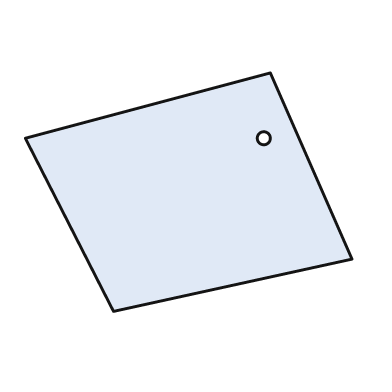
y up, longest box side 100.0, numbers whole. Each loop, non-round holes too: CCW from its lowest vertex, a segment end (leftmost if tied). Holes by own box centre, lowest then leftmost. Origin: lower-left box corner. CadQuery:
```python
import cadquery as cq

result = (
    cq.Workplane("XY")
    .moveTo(27.0, 0.0)
    .lineTo(100.0, 16.0)
    .lineTo(75.0, 73.0)
    .lineTo(0.0, 53.0)
    .close()
    .moveTo(73.0, 53.0)
    .circle(2.0)
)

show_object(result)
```